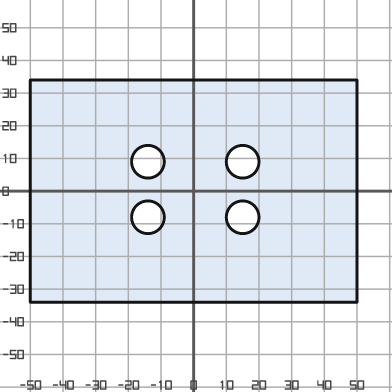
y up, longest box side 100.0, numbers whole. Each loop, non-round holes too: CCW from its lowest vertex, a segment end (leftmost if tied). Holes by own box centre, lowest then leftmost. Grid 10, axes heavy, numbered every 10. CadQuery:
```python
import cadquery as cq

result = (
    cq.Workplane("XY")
    .moveTo(-50.0, -34.0)
    .lineTo(50.0, -34.0)
    .lineTo(50.0, 34.0)
    .lineTo(-50.0, 34.0)
    .close()
    .moveTo(-14.0, -8.0)
    .circle(5.0)
    .moveTo(15.0, -8.0)
    .circle(5.0)
    .moveTo(-14.0, 9.0)
    .circle(5.0)
    .moveTo(15.0, 9.0)
    .circle(5.0)
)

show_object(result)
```